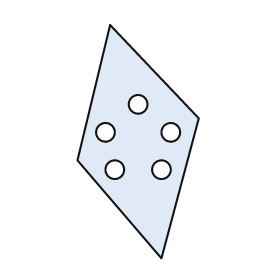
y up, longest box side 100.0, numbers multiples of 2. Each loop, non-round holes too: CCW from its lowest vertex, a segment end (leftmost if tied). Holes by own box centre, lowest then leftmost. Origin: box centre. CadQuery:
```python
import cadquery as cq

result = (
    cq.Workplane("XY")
    .moveTo(10.0, -50.0)
    .lineTo(26.0, 10.0)
    .lineTo(-12.0, 50.0)
    .lineTo(-26.0, -8.0)
    .close()
    .moveTo(-10.0, -12.0)
    .circle(4.0)
    .moveTo(10.0, -12.0)
    .circle(4.0)
    .moveTo(-14.0, 4.0)
    .circle(4.0)
    .moveTo(14.0, 4.0)
    .circle(4.0)
    .moveTo(0.0, 16.0)
    .circle(4.0)
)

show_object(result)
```